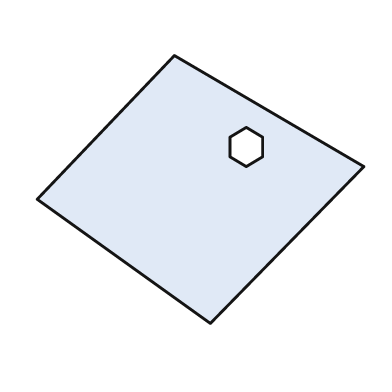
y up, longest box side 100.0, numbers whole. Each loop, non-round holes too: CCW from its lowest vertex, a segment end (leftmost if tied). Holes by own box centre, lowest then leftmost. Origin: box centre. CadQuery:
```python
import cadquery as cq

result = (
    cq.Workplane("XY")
    .moveTo(3.0, -41.0)
    .lineTo(50.0, 7.0)
    .lineTo(-8.0, 41.0)
    .lineTo(-50.0, -3.0)
    .close()
    .moveTo(14.0, 7.0)
    .lineTo(19.0, 10.0)
    .lineTo(19.0, 16.0)
    .lineTo(14.0, 19.0)
    .lineTo(9.0, 16.0)
    .lineTo(9.0, 10.0)
    .close()
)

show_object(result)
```